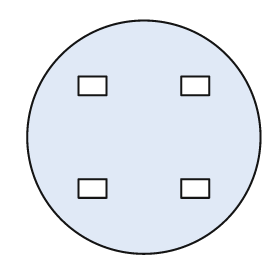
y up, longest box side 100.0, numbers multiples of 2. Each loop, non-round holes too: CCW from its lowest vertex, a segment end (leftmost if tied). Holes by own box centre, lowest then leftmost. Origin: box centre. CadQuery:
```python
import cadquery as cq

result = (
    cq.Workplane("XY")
    .moveTo(0.0, 0.0)
    .circle(50.0)
    .moveTo(-28.0, -26.0)
    .lineTo(-16.0, -26.0)
    .lineTo(-16.0, -18.0)
    .lineTo(-28.0, -18.0)
    .close()
    .moveTo(16.0, -26.0)
    .lineTo(28.0, -26.0)
    .lineTo(28.0, -18.0)
    .lineTo(16.0, -18.0)
    .close()
    .moveTo(-28.0, 18.0)
    .lineTo(-16.0, 18.0)
    .lineTo(-16.0, 26.0)
    .lineTo(-28.0, 26.0)
    .close()
    .moveTo(16.0, 18.0)
    .lineTo(28.0, 18.0)
    .lineTo(28.0, 26.0)
    .lineTo(16.0, 26.0)
    .close()
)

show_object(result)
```